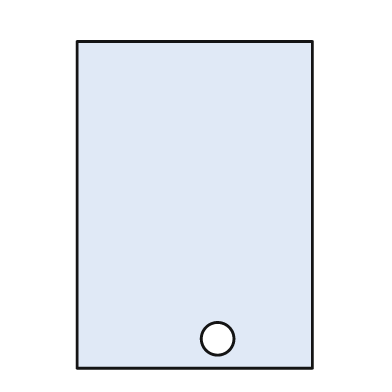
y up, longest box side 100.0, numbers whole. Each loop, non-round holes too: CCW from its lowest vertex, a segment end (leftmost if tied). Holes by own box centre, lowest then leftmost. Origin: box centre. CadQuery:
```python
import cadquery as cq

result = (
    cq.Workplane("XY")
    .moveTo(-36.0, -50.0)
    .lineTo(36.0, -50.0)
    .lineTo(36.0, 50.0)
    .lineTo(-36.0, 50.0)
    .close()
    .moveTo(7.0, -41.0)
    .circle(5.0)
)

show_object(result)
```